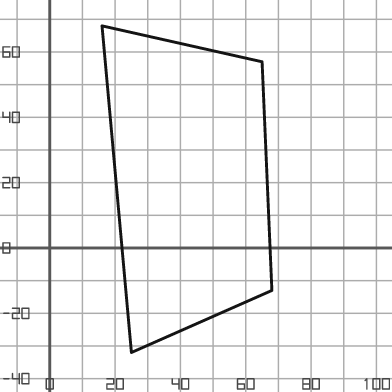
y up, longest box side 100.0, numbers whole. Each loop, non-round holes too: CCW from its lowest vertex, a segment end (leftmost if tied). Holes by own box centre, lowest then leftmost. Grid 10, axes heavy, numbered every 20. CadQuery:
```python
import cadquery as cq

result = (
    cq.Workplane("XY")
    .moveTo(25.0, -32.0)
    .lineTo(68.0, -13.0)
    .lineTo(65.0, 57.0)
    .lineTo(16.0, 68.0)
    .close()
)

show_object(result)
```